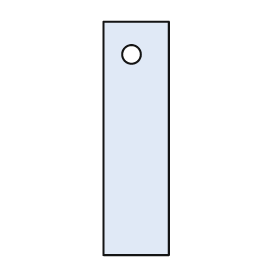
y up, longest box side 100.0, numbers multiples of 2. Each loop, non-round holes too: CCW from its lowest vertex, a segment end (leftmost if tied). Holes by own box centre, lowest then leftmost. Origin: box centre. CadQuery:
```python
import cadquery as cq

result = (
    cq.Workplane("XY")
    .moveTo(-14.0, -50.0)
    .lineTo(14.0, -50.0)
    .lineTo(14.0, 50.0)
    .lineTo(-14.0, 50.0)
    .close()
    .moveTo(-2.0, 36.0)
    .circle(4.0)
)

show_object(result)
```